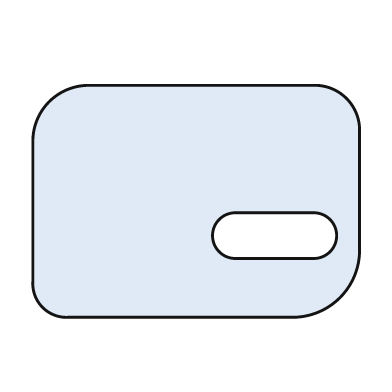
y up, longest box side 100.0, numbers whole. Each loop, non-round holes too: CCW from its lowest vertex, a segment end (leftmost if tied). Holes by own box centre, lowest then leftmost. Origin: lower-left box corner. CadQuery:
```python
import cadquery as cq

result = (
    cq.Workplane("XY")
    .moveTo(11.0, 0.0)
    .lineTo(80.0, 0.0)
    .threePointArc((94.0, 6.0), (100.0, 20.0))
    .lineTo(100.0, 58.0)
    .threePointArc((96.0, 67.0), (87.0, 71.0))
    .lineTo(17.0, 71.0)
    .threePointArc((5.0, 66.0), (0.0, 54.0))
    .lineTo(0.0, 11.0)
    .threePointArc((3.0, 3.0), (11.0, 0.0))
    .close()
    .moveTo(62.0, 18.0)
    .lineTo(86.0, 18.0)
    .threePointArc((93.0, 25.0), (86.0, 32.0))
    .lineTo(62.0, 32.0)
    .threePointArc((55.0, 25.0), (62.0, 18.0))
    .close()
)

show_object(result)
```